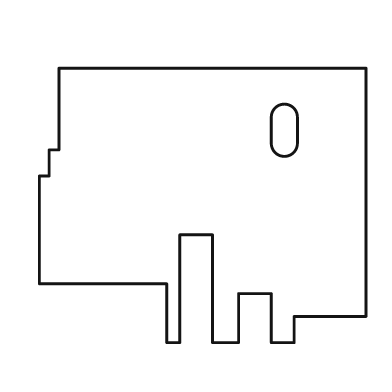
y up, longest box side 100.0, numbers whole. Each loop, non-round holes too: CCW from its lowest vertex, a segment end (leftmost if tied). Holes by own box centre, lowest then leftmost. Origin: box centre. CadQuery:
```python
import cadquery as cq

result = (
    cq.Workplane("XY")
    .moveTo(-11.0, -42.0)
    .lineTo(-7.0, -42.0)
    .lineTo(-7.0, -9.0)
    .lineTo(3.0, -9.0)
    .lineTo(3.0, -42.0)
    .lineTo(11.0, -42.0)
    .lineTo(11.0, -27.0)
    .lineTo(21.0, -27.0)
    .lineTo(21.0, -42.0)
    .lineTo(28.0, -42.0)
    .lineTo(28.0, -34.0)
    .lineTo(50.0, -34.0)
    .lineTo(50.0, 42.0)
    .lineTo(-44.0, 42.0)
    .lineTo(-44.0, 17.0)
    .lineTo(-47.0, 17.0)
    .lineTo(-47.0, 9.0)
    .lineTo(-50.0, 9.0)
    .lineTo(-50.0, -24.0)
    .lineTo(-11.0, -24.0)
    .close()
    .moveTo(21.0, 19.0)
    .threePointArc((25.0, 15.0), (29.0, 19.0))
    .lineTo(29.0, 27.0)
    .threePointArc((25.0, 31.0), (21.0, 27.0))
    .close()
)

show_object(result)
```